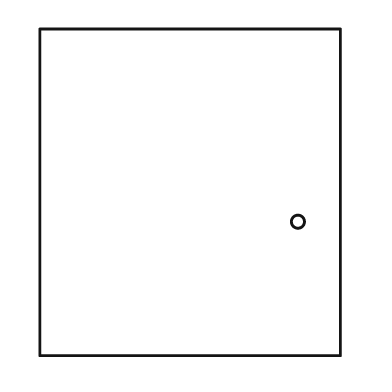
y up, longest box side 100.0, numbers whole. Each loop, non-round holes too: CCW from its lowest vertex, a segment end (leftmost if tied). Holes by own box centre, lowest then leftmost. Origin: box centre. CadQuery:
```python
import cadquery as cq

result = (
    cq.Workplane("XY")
    .moveTo(-46.0, -50.0)
    .lineTo(46.0, -50.0)
    .lineTo(46.0, 50.0)
    .lineTo(-46.0, 50.0)
    .close()
    .moveTo(33.0, -9.0)
    .circle(2.0)
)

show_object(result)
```